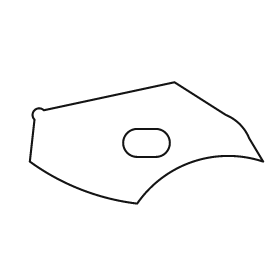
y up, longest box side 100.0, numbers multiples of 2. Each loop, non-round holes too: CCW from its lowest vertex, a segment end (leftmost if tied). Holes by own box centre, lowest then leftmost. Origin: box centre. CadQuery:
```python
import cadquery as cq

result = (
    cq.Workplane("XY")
    .moveTo(-4.0, -26.0)
    .threePointArc((20.0, -8.0), (50.0, -8.0))
    .lineTo(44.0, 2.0)
    .threePointArc((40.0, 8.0), (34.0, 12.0))
    .lineTo(12.0, 26.0)
    .lineTo(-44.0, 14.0)
    .threePointArc((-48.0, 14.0), (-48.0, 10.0))
    .lineTo(-50.0, -8.0)
    .threePointArc((-28.0, -20.0), (-4.0, -26.0))
    .close()
    .moveTo(-4.0, -6.0)
    .lineTo(4.0, -6.0)
    .threePointArc((10.0, 0.0), (4.0, 6.0))
    .lineTo(-4.0, 6.0)
    .threePointArc((-10.0, 0.0), (-4.0, -6.0))
    .close()
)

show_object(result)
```